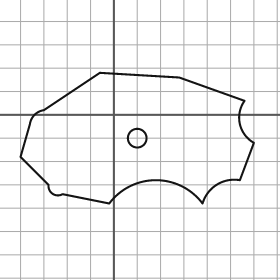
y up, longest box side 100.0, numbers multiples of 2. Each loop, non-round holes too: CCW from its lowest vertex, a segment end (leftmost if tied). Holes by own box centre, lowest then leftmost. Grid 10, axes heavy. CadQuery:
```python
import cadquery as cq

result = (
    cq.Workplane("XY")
    .moveTo(-2.0, -38.0)
    .threePointArc((18.0, -28.0), (38.0, -38.0))
    .threePointArc((44.0, -30.0), (54.0, -28.0))
    .lineTo(60.0, -12.0)
    .threePointArc((54.0, -4.0), (56.0, 6.0))
    .lineTo(28.0, 16.0)
    .lineTo(-6.0, 18.0)
    .lineTo(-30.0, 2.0)
    .threePointArc((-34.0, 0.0), (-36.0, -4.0))
    .lineTo(-40.0, -18.0)
    .lineTo(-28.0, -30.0)
    .threePointArc((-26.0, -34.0), (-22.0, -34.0))
    .close()
    .moveTo(10.0, -10.0)
    .circle(4.0)
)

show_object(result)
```